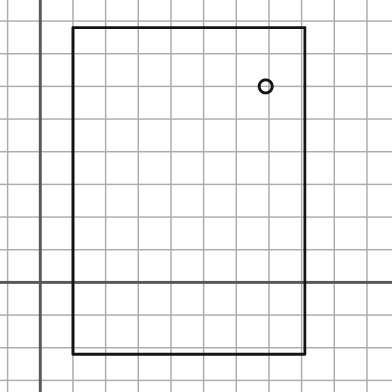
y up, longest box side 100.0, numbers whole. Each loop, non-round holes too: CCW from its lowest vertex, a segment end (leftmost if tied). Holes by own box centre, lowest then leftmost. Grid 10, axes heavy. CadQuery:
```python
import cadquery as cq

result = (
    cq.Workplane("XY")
    .moveTo(10.0, -22.0)
    .lineTo(81.0, -22.0)
    .lineTo(81.0, 78.0)
    .lineTo(10.0, 78.0)
    .close()
    .moveTo(69.0, 60.0)
    .circle(2.0)
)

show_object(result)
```